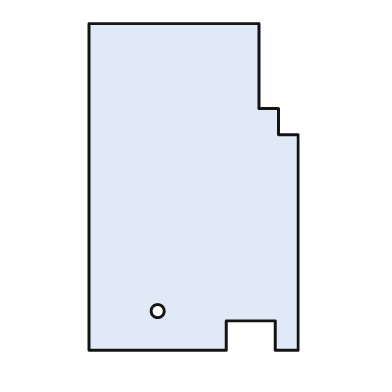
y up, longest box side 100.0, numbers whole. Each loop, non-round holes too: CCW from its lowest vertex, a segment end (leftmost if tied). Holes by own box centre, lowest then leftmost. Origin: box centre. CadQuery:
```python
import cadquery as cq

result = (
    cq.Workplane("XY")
    .moveTo(-32.0, -50.0)
    .lineTo(10.0, -50.0)
    .lineTo(10.0, -41.0)
    .lineTo(25.0, -41.0)
    .lineTo(25.0, -50.0)
    .lineTo(32.0, -50.0)
    .lineTo(32.0, 16.0)
    .lineTo(26.0, 16.0)
    .lineTo(26.0, 24.0)
    .lineTo(20.0, 24.0)
    .lineTo(20.0, 50.0)
    .lineTo(-32.0, 50.0)
    .close()
    .moveTo(-11.0, -38.0)
    .circle(2.0)
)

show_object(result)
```